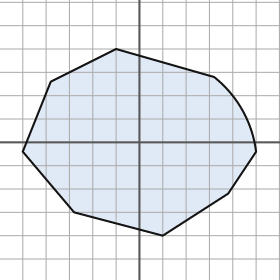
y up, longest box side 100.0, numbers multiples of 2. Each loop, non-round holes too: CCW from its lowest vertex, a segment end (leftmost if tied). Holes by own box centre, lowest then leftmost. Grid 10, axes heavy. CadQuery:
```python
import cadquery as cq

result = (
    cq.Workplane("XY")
    .moveTo(10.0, -40.0)
    .lineTo(38.0, -22.0)
    .lineTo(50.0, -4.0)
    .threePointArc((44.0, 14.0), (32.0, 28.0))
    .lineTo(-10.0, 40.0)
    .lineTo(-38.0, 26.0)
    .lineTo(-50.0, -4.0)
    .lineTo(-28.0, -30.0)
    .close()
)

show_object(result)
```